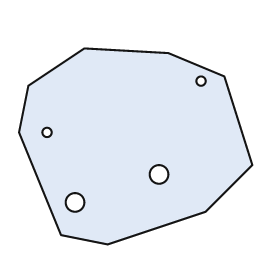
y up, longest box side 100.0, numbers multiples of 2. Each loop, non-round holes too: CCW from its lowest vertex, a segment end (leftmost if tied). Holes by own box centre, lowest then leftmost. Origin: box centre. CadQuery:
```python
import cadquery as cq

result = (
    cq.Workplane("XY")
    .moveTo(-12.0, -42.0)
    .lineTo(30.0, -28.0)
    .lineTo(50.0, -8.0)
    .lineTo(38.0, 30.0)
    .lineTo(14.0, 40.0)
    .lineTo(-22.0, 42.0)
    .lineTo(-46.0, 26.0)
    .lineTo(-50.0, 6.0)
    .lineTo(-32.0, -38.0)
    .close()
    .moveTo(-26.0, -24.0)
    .circle(4.0)
    .moveTo(10.0, -12.0)
    .circle(4.0)
    .moveTo(-38.0, 6.0)
    .circle(2.0)
    .moveTo(28.0, 28.0)
    .circle(2.0)
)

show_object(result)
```